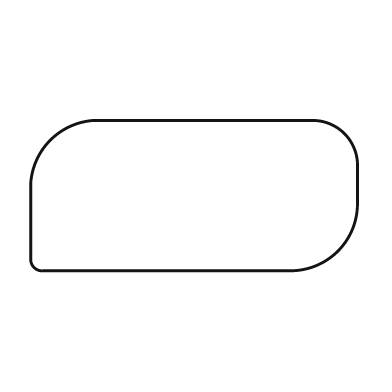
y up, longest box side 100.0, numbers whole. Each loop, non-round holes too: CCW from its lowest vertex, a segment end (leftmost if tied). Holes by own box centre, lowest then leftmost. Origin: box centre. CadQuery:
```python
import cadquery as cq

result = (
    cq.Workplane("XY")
    .moveTo(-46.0, -23.0)
    .lineTo(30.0, -23.0)
    .threePointArc((44.0, -17.0), (50.0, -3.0))
    .lineTo(50.0, 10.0)
    .threePointArc((46.0, 19.0), (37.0, 23.0))
    .lineTo(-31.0, 23.0)
    .threePointArc((-44.0, 17.0), (-50.0, 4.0))
    .lineTo(-50.0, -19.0)
    .threePointArc((-49.0, -22.0), (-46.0, -23.0))
    .close()
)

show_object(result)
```